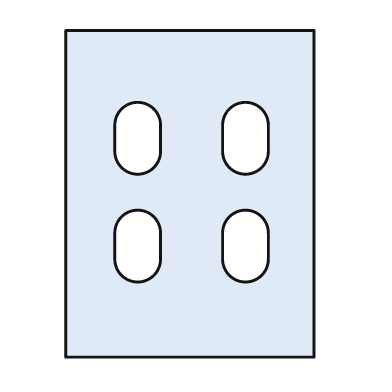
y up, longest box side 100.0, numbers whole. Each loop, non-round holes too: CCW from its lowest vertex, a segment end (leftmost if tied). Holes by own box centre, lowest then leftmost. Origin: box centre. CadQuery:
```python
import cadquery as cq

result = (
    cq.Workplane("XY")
    .moveTo(-38.0, -50.0)
    .lineTo(38.0, -50.0)
    .lineTo(38.0, 50.0)
    .lineTo(-38.0, 50.0)
    .close()
    .moveTo(-23.0, -20.0)
    .threePointArc((-16.0, -27.0), (-9.0, -20.0))
    .lineTo(-9.0, -12.0)
    .threePointArc((-16.0, -5.0), (-23.0, -12.0))
    .close()
    .moveTo(10.0, -20.0)
    .threePointArc((17.0, -27.0), (24.0, -20.0))
    .lineTo(24.0, -12.0)
    .threePointArc((17.0, -5.0), (10.0, -12.0))
    .close()
    .moveTo(-23.0, 13.0)
    .threePointArc((-16.0, 6.0), (-9.0, 13.0))
    .lineTo(-9.0, 21.0)
    .threePointArc((-16.0, 28.0), (-23.0, 21.0))
    .close()
    .moveTo(10.0, 13.0)
    .threePointArc((17.0, 6.0), (24.0, 13.0))
    .lineTo(24.0, 21.0)
    .threePointArc((17.0, 28.0), (10.0, 21.0))
    .close()
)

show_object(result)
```